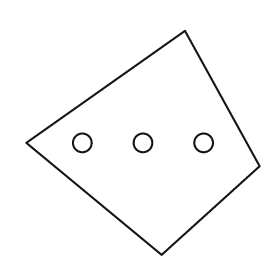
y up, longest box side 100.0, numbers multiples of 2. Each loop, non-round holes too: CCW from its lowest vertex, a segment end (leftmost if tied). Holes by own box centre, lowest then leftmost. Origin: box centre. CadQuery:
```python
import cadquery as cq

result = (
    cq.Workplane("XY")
    .moveTo(8.0, -48.0)
    .lineTo(50.0, -10.0)
    .lineTo(18.0, 48.0)
    .lineTo(-50.0, 0.0)
    .close()
    .moveTo(-26.0, 0.0)
    .circle(4.0)
    .moveTo(0.0, 0.0)
    .circle(4.0)
    .moveTo(26.0, 0.0)
    .circle(4.0)
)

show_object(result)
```